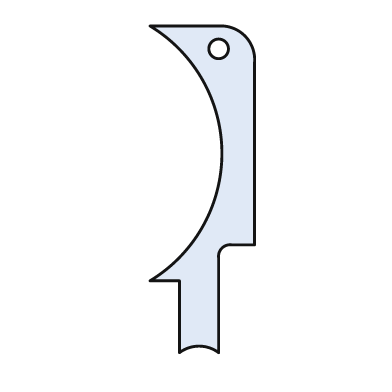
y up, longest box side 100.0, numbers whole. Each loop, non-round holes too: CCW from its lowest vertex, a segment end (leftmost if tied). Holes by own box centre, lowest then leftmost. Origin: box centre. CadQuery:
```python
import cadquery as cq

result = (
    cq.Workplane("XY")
    .moveTo(-7.0, -50.0)
    .threePointArc((-1.0, -48.0), (5.0, -50.0))
    .lineTo(5.0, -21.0)
    .threePointArc((6.0, -18.0), (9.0, -17.0))
    .lineTo(16.0, -17.0)
    .lineTo(16.0, 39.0)
    .threePointArc((13.0, 47.0), (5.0, 50.0))
    .lineTo(-16.0, 50.0)
    .threePointArc((6.0, 11.0), (-16.0, -28.0))
    .lineTo(-7.0, -28.0)
    .close()
    .moveTo(5.0, 43.0)
    .circle(3.0)
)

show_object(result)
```